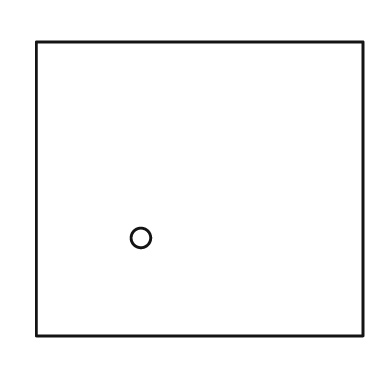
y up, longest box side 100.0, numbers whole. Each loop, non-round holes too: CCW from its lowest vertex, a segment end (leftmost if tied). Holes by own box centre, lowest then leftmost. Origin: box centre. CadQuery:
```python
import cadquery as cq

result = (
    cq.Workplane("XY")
    .moveTo(-50.0, -45.0)
    .lineTo(50.0, -45.0)
    .lineTo(50.0, 45.0)
    .lineTo(-50.0, 45.0)
    .close()
    .moveTo(-18.0, -15.0)
    .circle(3.0)
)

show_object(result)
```